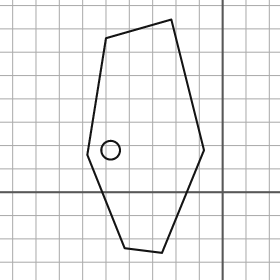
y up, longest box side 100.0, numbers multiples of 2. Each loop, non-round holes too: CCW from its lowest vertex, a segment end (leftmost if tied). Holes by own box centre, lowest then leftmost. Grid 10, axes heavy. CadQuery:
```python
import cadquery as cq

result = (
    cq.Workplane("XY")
    .moveTo(-26.0, -26.0)
    .lineTo(-8.0, 18.0)
    .lineTo(-22.0, 74.0)
    .lineTo(-50.0, 66.0)
    .lineTo(-58.0, 16.0)
    .lineTo(-42.0, -24.0)
    .close()
    .moveTo(-48.0, 18.0)
    .circle(4.0)
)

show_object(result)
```